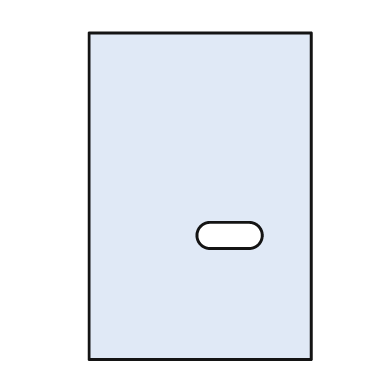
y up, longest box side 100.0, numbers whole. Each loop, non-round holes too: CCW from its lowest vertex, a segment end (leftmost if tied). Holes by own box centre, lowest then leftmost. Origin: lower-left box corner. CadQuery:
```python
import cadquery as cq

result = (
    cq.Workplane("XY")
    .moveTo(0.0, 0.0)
    .lineTo(68.0, 0.0)
    .lineTo(68.0, 100.0)
    .lineTo(0.0, 100.0)
    .close()
    .moveTo(37.0, 34.0)
    .lineTo(49.0, 34.0)
    .threePointArc((53.0, 38.0), (49.0, 42.0))
    .lineTo(37.0, 42.0)
    .threePointArc((33.0, 38.0), (37.0, 34.0))
    .close()
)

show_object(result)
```